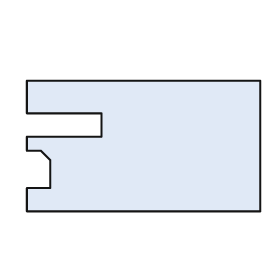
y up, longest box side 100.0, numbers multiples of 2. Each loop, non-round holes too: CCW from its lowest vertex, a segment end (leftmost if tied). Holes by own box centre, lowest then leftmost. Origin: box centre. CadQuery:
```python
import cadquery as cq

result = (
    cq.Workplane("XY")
    .moveTo(-50.0, -28.0)
    .lineTo(50.0, -28.0)
    .lineTo(50.0, 28.0)
    .lineTo(-50.0, 28.0)
    .lineTo(-50.0, 14.0)
    .lineTo(-18.0, 14.0)
    .lineTo(-18.0, 4.0)
    .lineTo(-50.0, 4.0)
    .lineTo(-50.0, -2.0)
    .lineTo(-44.0, -2.0)
    .lineTo(-40.0, -6.0)
    .lineTo(-40.0, -18.0)
    .lineTo(-50.0, -18.0)
    .close()
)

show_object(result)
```